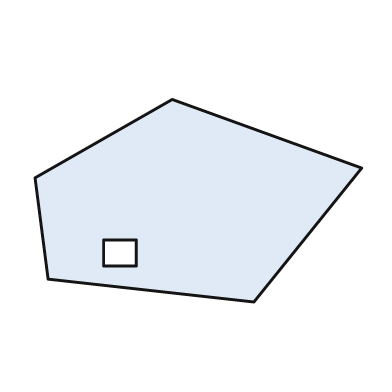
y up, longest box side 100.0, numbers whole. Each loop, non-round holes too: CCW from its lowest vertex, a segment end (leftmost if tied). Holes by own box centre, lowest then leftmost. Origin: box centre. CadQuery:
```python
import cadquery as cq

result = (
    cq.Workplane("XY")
    .moveTo(17.0, -31.0)
    .lineTo(50.0, 10.0)
    .lineTo(-8.0, 31.0)
    .lineTo(-50.0, 7.0)
    .lineTo(-46.0, -24.0)
    .close()
    .moveTo(-29.0, -20.0)
    .lineTo(-19.0, -20.0)
    .lineTo(-19.0, -12.0)
    .lineTo(-29.0, -12.0)
    .close()
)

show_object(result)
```